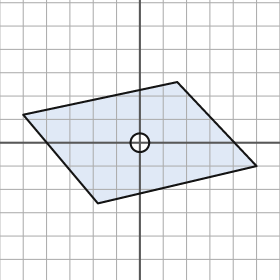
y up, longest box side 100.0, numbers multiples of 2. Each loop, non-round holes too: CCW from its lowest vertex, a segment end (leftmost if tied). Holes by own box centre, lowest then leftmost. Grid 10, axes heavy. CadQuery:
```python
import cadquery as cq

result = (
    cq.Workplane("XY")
    .moveTo(-18.0, -26.0)
    .lineTo(50.0, -10.0)
    .lineTo(16.0, 26.0)
    .lineTo(-50.0, 12.0)
    .close()
    .moveTo(0.0, 0.0)
    .circle(4.0)
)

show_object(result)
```